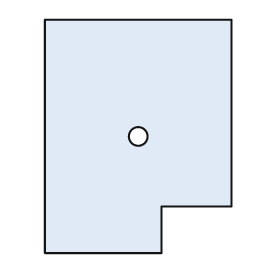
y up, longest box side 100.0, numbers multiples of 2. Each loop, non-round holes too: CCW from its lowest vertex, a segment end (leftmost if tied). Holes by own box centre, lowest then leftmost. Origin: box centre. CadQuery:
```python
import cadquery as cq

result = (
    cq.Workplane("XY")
    .moveTo(-40.0, -50.0)
    .lineTo(10.0, -50.0)
    .lineTo(10.0, -30.0)
    .lineTo(40.0, -30.0)
    .lineTo(40.0, 50.0)
    .lineTo(-40.0, 50.0)
    .close()
    .moveTo(0.0, 0.0)
    .circle(4.0)
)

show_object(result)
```